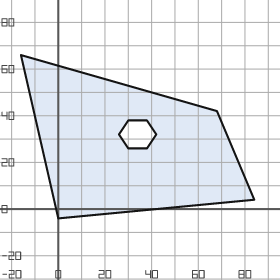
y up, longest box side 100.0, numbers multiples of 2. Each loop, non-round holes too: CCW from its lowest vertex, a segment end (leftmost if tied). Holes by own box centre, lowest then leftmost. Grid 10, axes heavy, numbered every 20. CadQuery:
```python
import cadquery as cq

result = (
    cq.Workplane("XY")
    .moveTo(0.0, -4.0)
    .lineTo(84.0, 4.0)
    .lineTo(68.0, 42.0)
    .lineTo(-16.0, 66.0)
    .close()
    .moveTo(30.0, 26.0)
    .lineTo(38.0, 26.0)
    .lineTo(42.0, 32.0)
    .lineTo(38.0, 38.0)
    .lineTo(30.0, 38.0)
    .lineTo(26.0, 32.0)
    .close()
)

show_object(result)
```